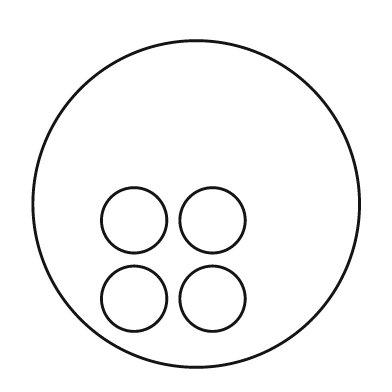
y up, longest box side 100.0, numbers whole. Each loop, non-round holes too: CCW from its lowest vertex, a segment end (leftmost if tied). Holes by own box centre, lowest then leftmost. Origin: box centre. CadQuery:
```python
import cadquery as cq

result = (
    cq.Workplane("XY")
    .moveTo(0.0, 0.0)
    .circle(50.0)
    .moveTo(-19.0, -29.0)
    .circle(10.0)
    .moveTo(5.0, -29.0)
    .circle(10.0)
    .moveTo(-19.0, -5.0)
    .circle(10.0)
    .moveTo(5.0, -5.0)
    .circle(10.0)
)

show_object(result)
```